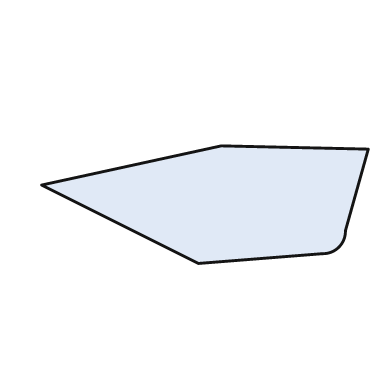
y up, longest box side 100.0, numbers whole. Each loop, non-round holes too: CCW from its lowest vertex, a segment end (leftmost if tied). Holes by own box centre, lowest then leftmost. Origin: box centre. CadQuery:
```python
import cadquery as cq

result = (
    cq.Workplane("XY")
    .moveTo(-2.0, -18.0)
    .lineTo(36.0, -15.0)
    .threePointArc((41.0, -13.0), (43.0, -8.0))
    .lineTo(50.0, 17.0)
    .lineTo(5.0, 18.0)
    .lineTo(-50.0, 6.0)
    .close()
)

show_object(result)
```